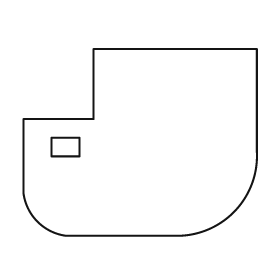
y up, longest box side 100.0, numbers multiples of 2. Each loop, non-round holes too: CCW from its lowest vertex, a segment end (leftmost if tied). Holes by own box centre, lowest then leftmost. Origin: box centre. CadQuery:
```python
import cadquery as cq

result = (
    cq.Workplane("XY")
    .moveTo(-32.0, -40.0)
    .lineTo(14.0, -40.0)
    .threePointArc((40.0, -30.0), (50.0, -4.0))
    .lineTo(50.0, 40.0)
    .lineTo(-20.0, 40.0)
    .lineTo(-20.0, 10.0)
    .lineTo(-50.0, 10.0)
    .lineTo(-50.0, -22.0)
    .threePointArc((-44.0, -34.0), (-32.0, -40.0))
    .close()
    .moveTo(-38.0, -6.0)
    .lineTo(-26.0, -6.0)
    .lineTo(-26.0, 2.0)
    .lineTo(-38.0, 2.0)
    .close()
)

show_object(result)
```